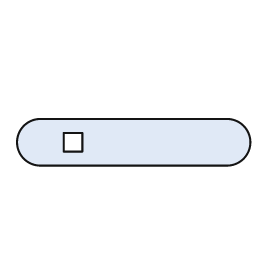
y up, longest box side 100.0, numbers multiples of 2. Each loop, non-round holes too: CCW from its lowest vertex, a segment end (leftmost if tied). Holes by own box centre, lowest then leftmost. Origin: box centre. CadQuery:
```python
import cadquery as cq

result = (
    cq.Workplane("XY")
    .moveTo(-40.0, -10.0)
    .lineTo(40.0, -10.0)
    .threePointArc((50.0, 0.0), (40.0, 10.0))
    .lineTo(-40.0, 10.0)
    .threePointArc((-50.0, 0.0), (-40.0, -10.0))
    .close()
    .moveTo(-30.0, -4.0)
    .lineTo(-22.0, -4.0)
    .lineTo(-22.0, 4.0)
    .lineTo(-30.0, 4.0)
    .close()
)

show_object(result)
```